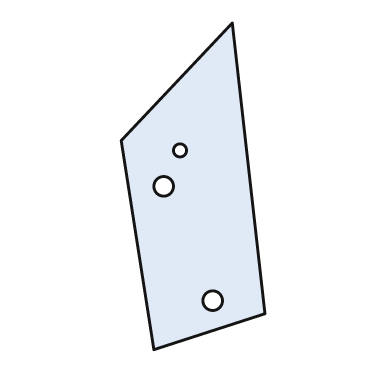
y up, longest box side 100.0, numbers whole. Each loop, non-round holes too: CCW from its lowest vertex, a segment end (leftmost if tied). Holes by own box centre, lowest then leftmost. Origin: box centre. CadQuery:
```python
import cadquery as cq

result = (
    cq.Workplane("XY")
    .moveTo(-12.0, -50.0)
    .lineTo(22.0, -39.0)
    .lineTo(12.0, 50.0)
    .lineTo(-22.0, 14.0)
    .close()
    .moveTo(6.0, -35.0)
    .circle(3.0)
    .moveTo(-9.0, 0.0)
    .circle(3.0)
    .moveTo(-4.0, 11.0)
    .circle(2.0)
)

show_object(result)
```